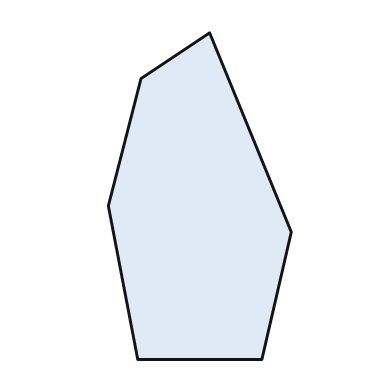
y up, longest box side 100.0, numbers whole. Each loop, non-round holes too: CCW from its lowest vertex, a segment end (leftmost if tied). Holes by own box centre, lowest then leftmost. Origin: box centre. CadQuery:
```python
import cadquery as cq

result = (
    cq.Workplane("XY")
    .moveTo(-19.0, -50.0)
    .lineTo(19.0, -50.0)
    .lineTo(28.0, -11.0)
    .lineTo(3.0, 50.0)
    .lineTo(-18.0, 36.0)
    .lineTo(-28.0, -3.0)
    .close()
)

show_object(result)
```